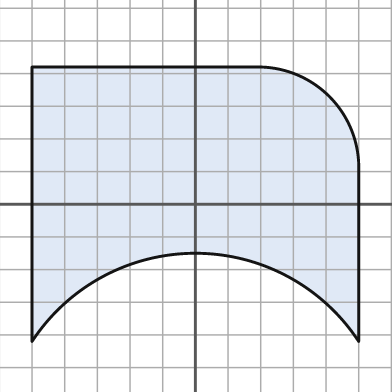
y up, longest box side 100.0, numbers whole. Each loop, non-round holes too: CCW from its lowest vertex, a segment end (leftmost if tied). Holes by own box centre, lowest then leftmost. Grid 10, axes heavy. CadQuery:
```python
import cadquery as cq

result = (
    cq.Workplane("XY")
    .moveTo(-50.0, -42.0)
    .threePointArc((0.0, -15.0), (50.0, -42.0))
    .lineTo(50.0, 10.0)
    .threePointArc((41.0, 33.0), (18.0, 42.0))
    .lineTo(-50.0, 42.0)
    .close()
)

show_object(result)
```